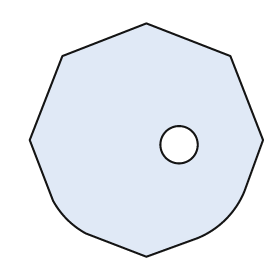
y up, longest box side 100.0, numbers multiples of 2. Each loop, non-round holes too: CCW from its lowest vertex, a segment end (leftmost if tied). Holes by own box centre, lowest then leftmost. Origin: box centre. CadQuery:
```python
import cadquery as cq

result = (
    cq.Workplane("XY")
    .moveTo(0.0, -50.0)
    .lineTo(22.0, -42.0)
    .threePointArc((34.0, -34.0), (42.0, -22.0))
    .lineTo(50.0, 0.0)
    .lineTo(36.0, 36.0)
    .lineTo(0.0, 50.0)
    .lineTo(-36.0, 36.0)
    .lineTo(-50.0, 0.0)
    .lineTo(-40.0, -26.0)
    .threePointArc((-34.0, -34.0), (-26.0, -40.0))
    .close()
    .moveTo(14.0, -2.0)
    .circle(8.0)
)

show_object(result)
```